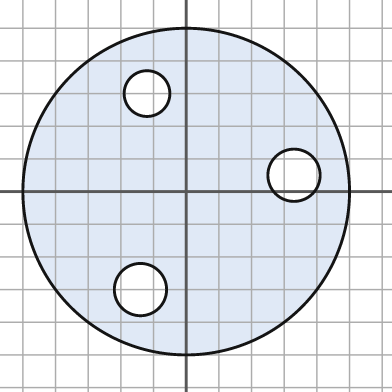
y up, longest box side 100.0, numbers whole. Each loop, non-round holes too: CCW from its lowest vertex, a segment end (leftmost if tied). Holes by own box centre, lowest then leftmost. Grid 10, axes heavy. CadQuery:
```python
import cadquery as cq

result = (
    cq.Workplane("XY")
    .moveTo(0.0, 0.0)
    .circle(50.0)
    .moveTo(-14.0, -30.0)
    .circle(8.0)
    .moveTo(33.0, 5.0)
    .circle(8.0)
    .moveTo(-12.0, 30.0)
    .circle(7.0)
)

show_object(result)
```